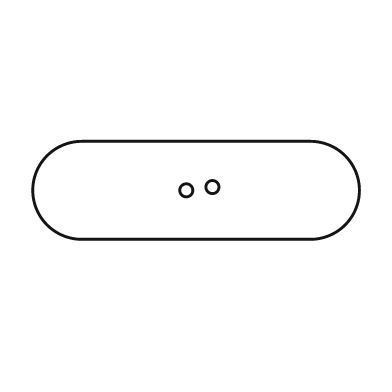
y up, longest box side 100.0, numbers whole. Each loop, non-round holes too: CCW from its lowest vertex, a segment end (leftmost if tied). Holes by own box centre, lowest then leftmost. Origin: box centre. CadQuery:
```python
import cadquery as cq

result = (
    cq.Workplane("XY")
    .moveTo(-35.0, -15.0)
    .lineTo(35.0, -15.0)
    .threePointArc((50.0, 0.0), (35.0, 15.0))
    .lineTo(-35.0, 15.0)
    .threePointArc((-50.0, 0.0), (-35.0, -15.0))
    .close()
    .moveTo(-3.0, 0.0)
    .circle(2.0)
    .moveTo(5.0, 1.0)
    .circle(2.0)
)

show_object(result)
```